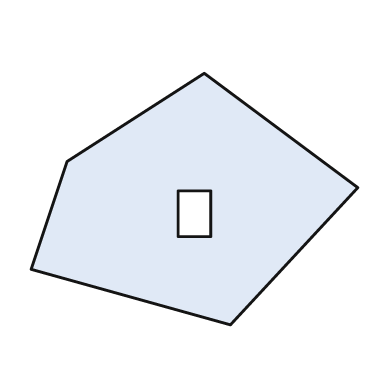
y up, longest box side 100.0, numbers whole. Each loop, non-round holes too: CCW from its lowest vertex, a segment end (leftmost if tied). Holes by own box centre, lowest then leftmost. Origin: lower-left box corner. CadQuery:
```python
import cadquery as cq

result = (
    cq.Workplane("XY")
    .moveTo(61.0, 0.0)
    .lineTo(100.0, 42.0)
    .lineTo(53.0, 77.0)
    .lineTo(11.0, 50.0)
    .lineTo(0.0, 17.0)
    .close()
    .moveTo(45.0, 27.0)
    .lineTo(55.0, 27.0)
    .lineTo(55.0, 41.0)
    .lineTo(45.0, 41.0)
    .close()
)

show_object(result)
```